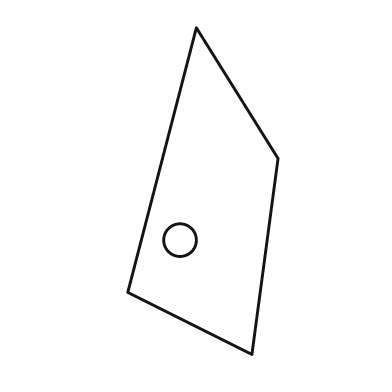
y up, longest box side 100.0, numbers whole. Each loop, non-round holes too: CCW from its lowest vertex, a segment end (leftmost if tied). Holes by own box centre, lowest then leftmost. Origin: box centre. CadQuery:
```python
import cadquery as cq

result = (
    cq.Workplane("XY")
    .moveTo(15.0, -50.0)
    .lineTo(23.0, 10.0)
    .lineTo(-2.0, 50.0)
    .lineTo(-23.0, -31.0)
    .close()
    .moveTo(-7.0, -15.0)
    .circle(5.0)
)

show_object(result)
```